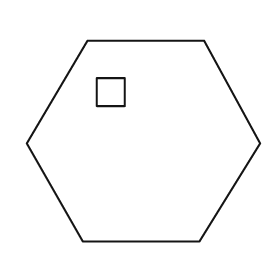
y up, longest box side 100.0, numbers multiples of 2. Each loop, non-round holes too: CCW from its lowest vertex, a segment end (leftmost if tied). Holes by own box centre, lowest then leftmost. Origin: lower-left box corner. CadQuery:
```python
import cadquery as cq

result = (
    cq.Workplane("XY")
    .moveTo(24.0, 0.0)
    .lineTo(74.0, 0.0)
    .lineTo(100.0, 42.0)
    .lineTo(76.0, 86.0)
    .lineTo(26.0, 86.0)
    .lineTo(0.0, 42.0)
    .close()
    .moveTo(30.0, 58.0)
    .lineTo(42.0, 58.0)
    .lineTo(42.0, 70.0)
    .lineTo(30.0, 70.0)
    .close()
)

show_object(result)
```